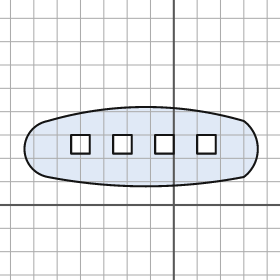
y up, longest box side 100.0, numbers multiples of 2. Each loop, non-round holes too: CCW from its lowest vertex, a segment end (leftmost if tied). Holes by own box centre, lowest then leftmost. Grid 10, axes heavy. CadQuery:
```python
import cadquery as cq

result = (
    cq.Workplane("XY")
    .moveTo(-54.0, 12.0)
    .threePointArc((-12.0, 8.0), (30.0, 12.0))
    .threePointArc((36.0, 24.0), (30.0, 36.0))
    .threePointArc((-12.0, 42.0), (-54.0, 36.0))
    .threePointArc((-64.0, 24.0), (-54.0, 12.0))
    .close()
    .moveTo(-44.0, 22.0)
    .lineTo(-36.0, 22.0)
    .lineTo(-36.0, 30.0)
    .lineTo(-44.0, 30.0)
    .close()
    .moveTo(-26.0, 22.0)
    .lineTo(-18.0, 22.0)
    .lineTo(-18.0, 30.0)
    .lineTo(-26.0, 30.0)
    .close()
    .moveTo(-8.0, 22.0)
    .lineTo(0.0, 22.0)
    .lineTo(0.0, 30.0)
    .lineTo(-8.0, 30.0)
    .close()
    .moveTo(10.0, 22.0)
    .lineTo(18.0, 22.0)
    .lineTo(18.0, 30.0)
    .lineTo(10.0, 30.0)
    .close()
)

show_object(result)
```